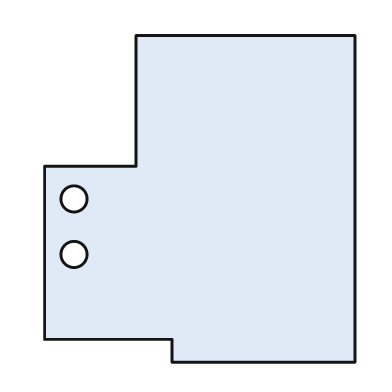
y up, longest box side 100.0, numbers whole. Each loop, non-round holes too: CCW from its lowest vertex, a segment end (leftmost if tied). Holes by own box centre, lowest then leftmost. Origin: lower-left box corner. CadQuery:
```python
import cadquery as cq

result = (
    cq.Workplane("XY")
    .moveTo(39.0, 0.0)
    .lineTo(95.0, 0.0)
    .lineTo(95.0, 100.0)
    .lineTo(28.0, 100.0)
    .lineTo(28.0, 60.0)
    .lineTo(0.0, 60.0)
    .lineTo(0.0, 7.0)
    .lineTo(39.0, 7.0)
    .close()
    .moveTo(9.0, 33.0)
    .circle(4.0)
    .moveTo(9.0, 50.0)
    .circle(4.0)
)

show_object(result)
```